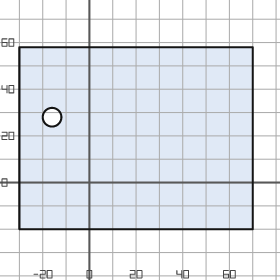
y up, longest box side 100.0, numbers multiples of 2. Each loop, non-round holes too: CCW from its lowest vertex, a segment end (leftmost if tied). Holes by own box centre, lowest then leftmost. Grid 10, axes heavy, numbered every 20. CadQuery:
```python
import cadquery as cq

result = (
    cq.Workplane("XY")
    .moveTo(-30.0, -20.0)
    .lineTo(70.0, -20.0)
    .lineTo(70.0, 58.0)
    .lineTo(-30.0, 58.0)
    .close()
    .moveTo(-16.0, 28.0)
    .circle(4.0)
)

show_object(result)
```